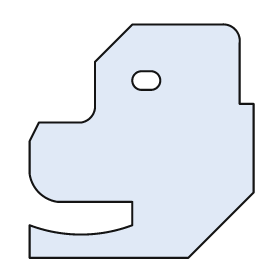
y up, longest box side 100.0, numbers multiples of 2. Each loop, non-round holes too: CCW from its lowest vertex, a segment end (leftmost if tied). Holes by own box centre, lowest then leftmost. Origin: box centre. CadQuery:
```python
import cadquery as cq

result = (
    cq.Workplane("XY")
    .moveTo(-48.0, -50.0)
    .lineTo(20.0, -50.0)
    .lineTo(48.0, -22.0)
    .lineTo(48.0, 16.0)
    .lineTo(42.0, 16.0)
    .lineTo(42.0, 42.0)
    .threePointArc((40.0, 48.0), (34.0, 50.0))
    .lineTo(-4.0, 50.0)
    .lineTo(-20.0, 34.0)
    .lineTo(-20.0, 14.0)
    .threePointArc((-22.0, 10.0), (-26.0, 8.0))
    .lineTo(-44.0, 8.0)
    .lineTo(-48.0, 0.0)
    .lineTo(-48.0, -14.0)
    .threePointArc((-44.0, -22.0), (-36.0, -26.0))
    .lineTo(-4.0, -26.0)
    .lineTo(-4.0, -36.0)
    .threePointArc((-26.0, -40.0), (-48.0, -36.0))
    .close()
    .moveTo(0.0, 22.0)
    .lineTo(4.0, 22.0)
    .threePointArc((8.0, 26.0), (4.0, 30.0))
    .lineTo(0.0, 30.0)
    .threePointArc((-4.0, 26.0), (0.0, 22.0))
    .close()
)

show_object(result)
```